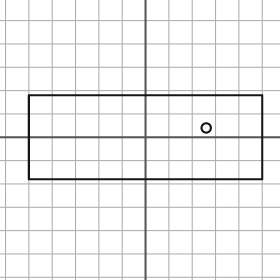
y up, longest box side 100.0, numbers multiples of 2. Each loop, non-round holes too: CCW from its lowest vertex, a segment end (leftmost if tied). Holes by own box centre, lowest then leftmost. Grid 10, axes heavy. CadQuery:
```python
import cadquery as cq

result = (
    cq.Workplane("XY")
    .moveTo(-50.0, -18.0)
    .lineTo(50.0, -18.0)
    .lineTo(50.0, 18.0)
    .lineTo(-50.0, 18.0)
    .close()
    .moveTo(26.0, 4.0)
    .circle(2.0)
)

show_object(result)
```